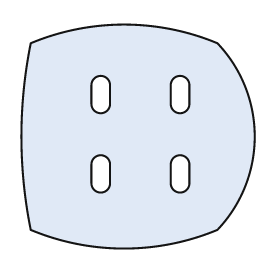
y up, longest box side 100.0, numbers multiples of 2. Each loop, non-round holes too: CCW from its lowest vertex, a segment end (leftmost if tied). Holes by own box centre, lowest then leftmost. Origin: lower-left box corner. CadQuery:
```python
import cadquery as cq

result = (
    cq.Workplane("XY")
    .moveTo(4.0, 8.0)
    .threePointArc((44.0, 0.0), (84.0, 8.0))
    .threePointArc((100.0, 48.0), (84.0, 88.0))
    .threePointArc((44.0, 96.0), (4.0, 88.0))
    .threePointArc((0.0, 48.0), (4.0, 8.0))
    .close()
    .moveTo(30.0, 28.0)
    .threePointArc((34.0, 24.0), (38.0, 28.0))
    .lineTo(38.0, 36.0)
    .threePointArc((34.0, 40.0), (30.0, 36.0))
    .close()
    .moveTo(64.0, 28.0)
    .threePointArc((68.0, 24.0), (72.0, 28.0))
    .lineTo(72.0, 36.0)
    .threePointArc((68.0, 40.0), (64.0, 36.0))
    .close()
    .moveTo(30.0, 62.0)
    .threePointArc((34.0, 58.0), (38.0, 62.0))
    .lineTo(38.0, 70.0)
    .threePointArc((34.0, 74.0), (30.0, 70.0))
    .close()
    .moveTo(64.0, 62.0)
    .threePointArc((68.0, 58.0), (72.0, 62.0))
    .lineTo(72.0, 70.0)
    .threePointArc((68.0, 74.0), (64.0, 70.0))
    .close()
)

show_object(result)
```